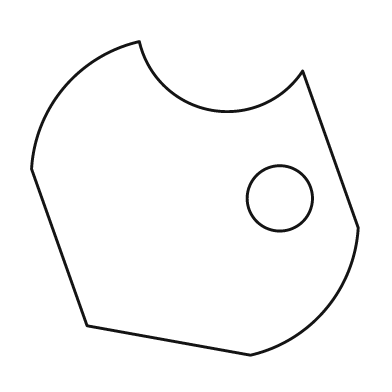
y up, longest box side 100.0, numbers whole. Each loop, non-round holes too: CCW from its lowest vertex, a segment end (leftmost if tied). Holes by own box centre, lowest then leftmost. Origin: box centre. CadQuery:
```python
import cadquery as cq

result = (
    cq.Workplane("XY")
    .moveTo(17.0, -48.0)
    .threePointArc((40.0, -34.0), (50.0, -9.0))
    .lineTo(33.0, 39.0)
    .threePointArc((5.0, 27.0), (-17.0, 48.0))
    .threePointArc((-40.0, 34.0), (-50.0, 9.0))
    .lineTo(-33.0, -39.0)
    .close()
    .moveTo(26.0, 0.0)
    .circle(10.0)
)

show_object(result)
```